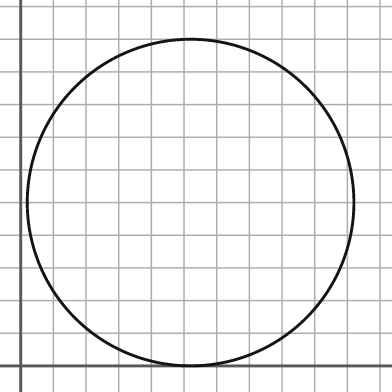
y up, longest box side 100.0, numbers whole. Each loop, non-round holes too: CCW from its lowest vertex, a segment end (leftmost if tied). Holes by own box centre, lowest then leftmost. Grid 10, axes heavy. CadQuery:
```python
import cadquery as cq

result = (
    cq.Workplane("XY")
    .moveTo(52.0, 50.0)
    .circle(50.0)
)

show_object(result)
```